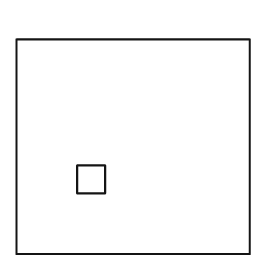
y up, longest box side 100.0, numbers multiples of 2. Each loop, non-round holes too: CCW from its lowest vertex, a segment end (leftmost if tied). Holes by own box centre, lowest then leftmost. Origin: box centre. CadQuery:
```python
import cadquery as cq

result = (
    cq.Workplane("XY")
    .moveTo(-50.0, -46.0)
    .lineTo(50.0, -46.0)
    .lineTo(50.0, 46.0)
    .lineTo(-50.0, 46.0)
    .close()
    .moveTo(-24.0, -20.0)
    .lineTo(-12.0, -20.0)
    .lineTo(-12.0, -8.0)
    .lineTo(-24.0, -8.0)
    .close()
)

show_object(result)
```